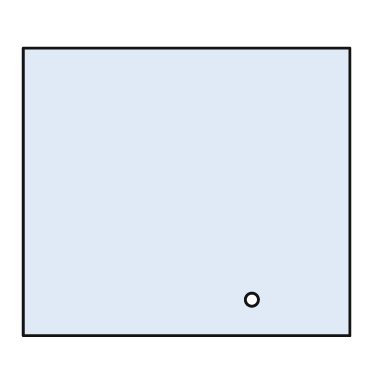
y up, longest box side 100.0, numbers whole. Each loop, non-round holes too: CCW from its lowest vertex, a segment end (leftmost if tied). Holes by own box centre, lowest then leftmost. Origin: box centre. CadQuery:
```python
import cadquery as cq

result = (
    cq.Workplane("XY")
    .moveTo(-50.0, -44.0)
    .lineTo(50.0, -44.0)
    .lineTo(50.0, 44.0)
    .lineTo(-50.0, 44.0)
    .close()
    .moveTo(20.0, -33.0)
    .circle(2.0)
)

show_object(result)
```